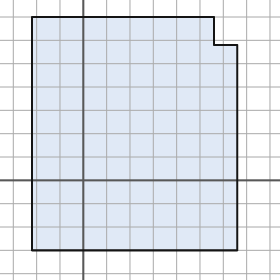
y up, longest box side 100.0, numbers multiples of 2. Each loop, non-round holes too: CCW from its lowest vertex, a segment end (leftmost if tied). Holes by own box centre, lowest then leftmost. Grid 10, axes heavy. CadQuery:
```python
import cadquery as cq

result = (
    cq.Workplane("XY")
    .moveTo(-22.0, -30.0)
    .lineTo(66.0, -30.0)
    .lineTo(66.0, 58.0)
    .lineTo(56.0, 58.0)
    .lineTo(56.0, 70.0)
    .lineTo(-22.0, 70.0)
    .close()
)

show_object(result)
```